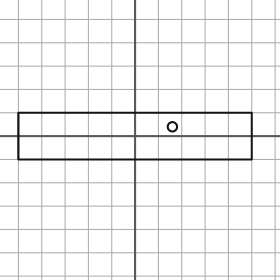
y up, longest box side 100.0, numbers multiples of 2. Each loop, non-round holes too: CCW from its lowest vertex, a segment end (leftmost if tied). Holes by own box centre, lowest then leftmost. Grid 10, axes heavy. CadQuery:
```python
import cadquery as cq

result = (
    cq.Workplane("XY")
    .moveTo(-50.0, -10.0)
    .lineTo(50.0, -10.0)
    .lineTo(50.0, 10.0)
    .lineTo(-50.0, 10.0)
    .close()
    .moveTo(16.0, 4.0)
    .circle(2.0)
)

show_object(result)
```